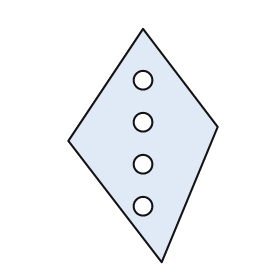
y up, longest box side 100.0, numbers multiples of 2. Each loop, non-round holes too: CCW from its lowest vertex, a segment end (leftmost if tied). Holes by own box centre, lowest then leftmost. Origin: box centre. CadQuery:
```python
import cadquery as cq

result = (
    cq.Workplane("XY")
    .moveTo(8.0, -50.0)
    .lineTo(32.0, 8.0)
    .lineTo(0.0, 50.0)
    .lineTo(-32.0, 2.0)
    .close()
    .moveTo(0.0, -26.0)
    .circle(4.0)
    .moveTo(0.0, -8.0)
    .circle(4.0)
    .moveTo(0.0, 10.0)
    .circle(4.0)
    .moveTo(0.0, 28.0)
    .circle(4.0)
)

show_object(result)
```